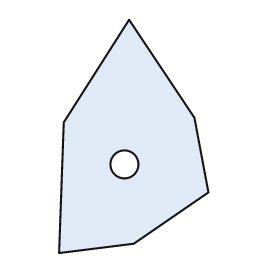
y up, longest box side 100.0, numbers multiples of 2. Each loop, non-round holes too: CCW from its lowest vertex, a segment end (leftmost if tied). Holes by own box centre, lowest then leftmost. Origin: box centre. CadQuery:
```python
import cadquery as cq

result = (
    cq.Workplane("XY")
    .moveTo(-32.0, -50.0)
    .lineTo(0.0, -46.0)
    .lineTo(32.0, -24.0)
    .lineTo(26.0, 8.0)
    .lineTo(-2.0, 50.0)
    .lineTo(-30.0, 6.0)
    .close()
    .moveTo(-4.0, -12.0)
    .circle(6.0)
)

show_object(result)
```